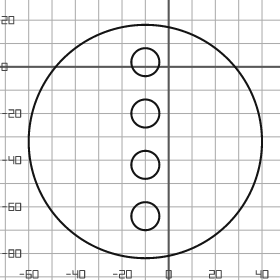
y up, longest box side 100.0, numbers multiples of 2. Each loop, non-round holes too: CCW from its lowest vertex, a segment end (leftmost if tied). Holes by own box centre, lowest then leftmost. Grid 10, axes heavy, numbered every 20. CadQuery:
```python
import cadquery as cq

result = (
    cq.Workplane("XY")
    .moveTo(-10.0, -32.0)
    .circle(50.0)
    .moveTo(-10.0, -64.0)
    .circle(6.0)
    .moveTo(-10.0, -42.0)
    .circle(6.0)
    .moveTo(-10.0, -20.0)
    .circle(6.0)
    .moveTo(-10.0, 2.0)
    .circle(6.0)
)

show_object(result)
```